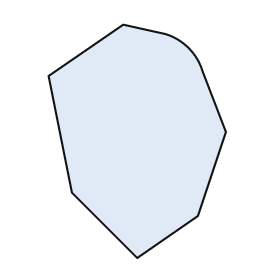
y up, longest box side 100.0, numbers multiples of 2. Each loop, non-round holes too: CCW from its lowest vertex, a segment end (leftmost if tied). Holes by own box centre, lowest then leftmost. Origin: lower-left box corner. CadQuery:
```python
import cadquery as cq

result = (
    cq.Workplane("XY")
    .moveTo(38.0, 0.0)
    .lineTo(64.0, 18.0)
    .lineTo(76.0, 54.0)
    .lineTo(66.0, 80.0)
    .threePointArc((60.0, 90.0), (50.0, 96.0))
    .lineTo(32.0, 100.0)
    .lineTo(0.0, 78.0)
    .lineTo(10.0, 28.0)
    .close()
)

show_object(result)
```